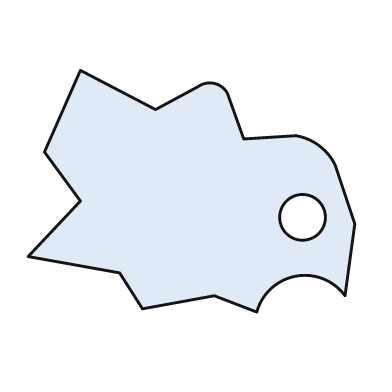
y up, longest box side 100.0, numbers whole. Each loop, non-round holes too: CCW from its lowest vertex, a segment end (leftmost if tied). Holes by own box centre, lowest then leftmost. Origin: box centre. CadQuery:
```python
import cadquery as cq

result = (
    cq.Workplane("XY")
    .moveTo(20.0, -37.0)
    .threePointArc((32.0, -26.0), (47.0, -32.0))
    .lineTo(50.0, -10.0)
    .lineTo(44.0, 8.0)
    .threePointArc((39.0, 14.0), (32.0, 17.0))
    .lineTo(16.0, 16.0)
    .lineTo(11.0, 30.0)
    .threePointArc((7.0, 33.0), (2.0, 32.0))
    .lineTo(-11.0, 25.0)
    .lineTo(-34.0, 37.0)
    .lineTo(-45.0, 12.0)
    .lineTo(-34.0, -3.0)
    .lineTo(-50.0, -20.0)
    .lineTo(-22.0, -25.0)
    .lineTo(-15.0, -36.0)
    .lineTo(7.0, -32.0)
    .close()
    .moveTo(34.0, -8.0)
    .circle(7.0)
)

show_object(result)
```